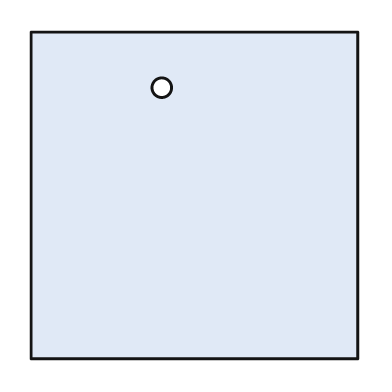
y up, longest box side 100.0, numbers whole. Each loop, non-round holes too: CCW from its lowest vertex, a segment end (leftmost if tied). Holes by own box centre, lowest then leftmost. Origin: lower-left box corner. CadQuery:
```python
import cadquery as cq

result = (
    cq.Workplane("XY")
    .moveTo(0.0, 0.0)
    .lineTo(100.0, 0.0)
    .lineTo(100.0, 100.0)
    .lineTo(0.0, 100.0)
    .close()
    .moveTo(40.0, 83.0)
    .circle(3.0)
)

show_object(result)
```